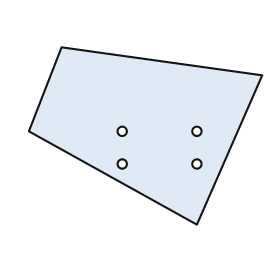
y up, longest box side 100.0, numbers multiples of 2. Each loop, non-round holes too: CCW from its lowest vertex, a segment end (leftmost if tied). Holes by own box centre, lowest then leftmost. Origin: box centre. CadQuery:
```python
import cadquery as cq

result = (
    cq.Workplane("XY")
    .moveTo(22.0, -38.0)
    .lineTo(50.0, 26.0)
    .lineTo(-36.0, 38.0)
    .lineTo(-50.0, 2.0)
    .close()
    .moveTo(-10.0, -12.0)
    .circle(2.0)
    .moveTo(22.0, -12.0)
    .circle(2.0)
    .moveTo(-10.0, 2.0)
    .circle(2.0)
    .moveTo(22.0, 2.0)
    .circle(2.0)
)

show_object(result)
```